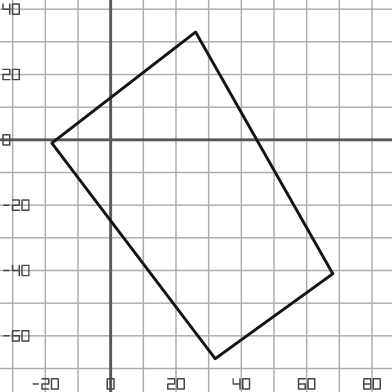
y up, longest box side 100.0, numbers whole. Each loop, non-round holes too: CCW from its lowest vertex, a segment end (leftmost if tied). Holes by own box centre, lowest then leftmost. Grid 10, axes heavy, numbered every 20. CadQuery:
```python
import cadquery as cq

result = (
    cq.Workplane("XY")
    .moveTo(32.0, -67.0)
    .lineTo(68.0, -41.0)
    .lineTo(26.0, 33.0)
    .lineTo(-18.0, -1.0)
    .close()
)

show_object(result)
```